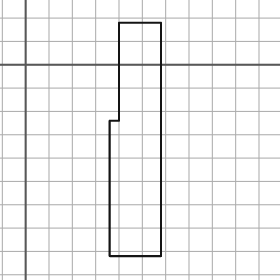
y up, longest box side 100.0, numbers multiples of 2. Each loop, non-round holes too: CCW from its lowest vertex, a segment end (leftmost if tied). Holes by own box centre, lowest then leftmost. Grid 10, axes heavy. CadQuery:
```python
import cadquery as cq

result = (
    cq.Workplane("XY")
    .moveTo(36.0, -82.0)
    .lineTo(58.0, -82.0)
    .lineTo(58.0, 18.0)
    .lineTo(40.0, 18.0)
    .lineTo(40.0, -24.0)
    .lineTo(36.0, -24.0)
    .close()
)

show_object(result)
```